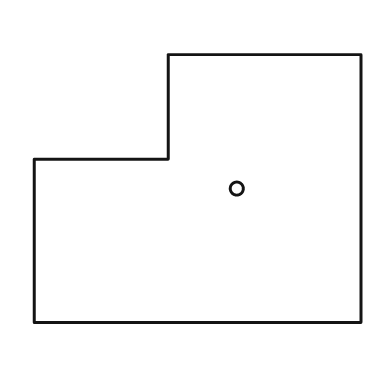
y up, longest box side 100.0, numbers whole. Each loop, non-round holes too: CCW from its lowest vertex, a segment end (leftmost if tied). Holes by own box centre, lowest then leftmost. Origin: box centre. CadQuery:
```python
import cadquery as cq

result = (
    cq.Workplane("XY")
    .moveTo(-50.0, -41.0)
    .lineTo(50.0, -41.0)
    .lineTo(50.0, 41.0)
    .lineTo(-9.0, 41.0)
    .lineTo(-9.0, 9.0)
    .lineTo(-50.0, 9.0)
    .close()
    .moveTo(12.0, 0.0)
    .circle(2.0)
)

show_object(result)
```